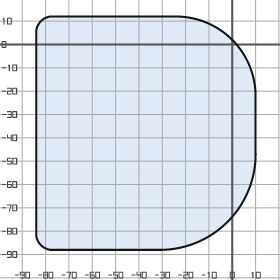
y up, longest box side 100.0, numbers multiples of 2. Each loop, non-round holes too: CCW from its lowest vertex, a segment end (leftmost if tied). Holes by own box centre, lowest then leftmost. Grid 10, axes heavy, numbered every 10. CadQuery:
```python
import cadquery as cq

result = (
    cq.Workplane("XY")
    .moveTo(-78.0, -88.0)
    .lineTo(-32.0, -88.0)
    .threePointArc((-2.0, -76.0), (10.0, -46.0))
    .lineTo(10.0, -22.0)
    .threePointArc((0.0, 2.0), (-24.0, 12.0))
    .lineTo(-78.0, 12.0)
    .threePointArc((-82.0, 10.0), (-84.0, 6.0))
    .lineTo(-84.0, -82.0)
    .threePointArc((-82.0, -86.0), (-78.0, -88.0))
    .close()
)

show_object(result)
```